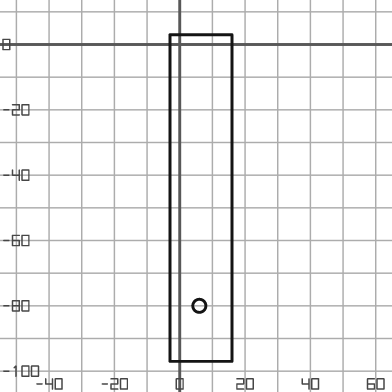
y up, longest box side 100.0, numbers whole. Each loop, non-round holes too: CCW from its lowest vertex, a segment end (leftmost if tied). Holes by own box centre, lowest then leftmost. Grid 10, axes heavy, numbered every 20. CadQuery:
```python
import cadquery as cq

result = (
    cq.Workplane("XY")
    .moveTo(-3.0, -97.0)
    .lineTo(16.0, -97.0)
    .lineTo(16.0, 3.0)
    .lineTo(-3.0, 3.0)
    .close()
    .moveTo(6.0, -80.0)
    .circle(2.0)
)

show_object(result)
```